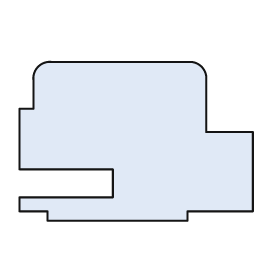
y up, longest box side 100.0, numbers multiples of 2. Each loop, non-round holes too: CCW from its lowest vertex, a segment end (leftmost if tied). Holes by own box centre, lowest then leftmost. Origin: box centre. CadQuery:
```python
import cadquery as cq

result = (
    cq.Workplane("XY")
    .moveTo(-38.0, -34.0)
    .lineTo(22.0, -34.0)
    .lineTo(22.0, -30.0)
    .lineTo(50.0, -30.0)
    .lineTo(50.0, 4.0)
    .lineTo(30.0, 4.0)
    .lineTo(30.0, 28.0)
    .threePointArc((28.0, 32.0), (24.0, 34.0))
    .lineTo(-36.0, 34.0)
    .threePointArc((-42.0, 32.0), (-44.0, 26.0))
    .lineTo(-44.0, 14.0)
    .lineTo(-50.0, 14.0)
    .lineTo(-50.0, -12.0)
    .lineTo(-10.0, -12.0)
    .lineTo(-10.0, -24.0)
    .lineTo(-50.0, -24.0)
    .lineTo(-50.0, -30.0)
    .lineTo(-38.0, -30.0)
    .close()
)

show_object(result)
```